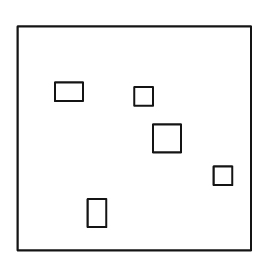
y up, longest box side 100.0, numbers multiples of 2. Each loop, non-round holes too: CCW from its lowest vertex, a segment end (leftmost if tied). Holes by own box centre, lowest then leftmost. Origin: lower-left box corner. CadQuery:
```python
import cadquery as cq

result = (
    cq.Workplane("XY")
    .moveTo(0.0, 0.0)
    .lineTo(100.0, 0.0)
    .lineTo(100.0, 96.0)
    .lineTo(0.0, 96.0)
    .close()
    .moveTo(30.0, 10.0)
    .lineTo(38.0, 10.0)
    .lineTo(38.0, 22.0)
    .lineTo(30.0, 22.0)
    .close()
    .moveTo(84.0, 28.0)
    .lineTo(92.0, 28.0)
    .lineTo(92.0, 36.0)
    .lineTo(84.0, 36.0)
    .close()
    .moveTo(58.0, 42.0)
    .lineTo(70.0, 42.0)
    .lineTo(70.0, 54.0)
    .lineTo(58.0, 54.0)
    .close()
    .moveTo(50.0, 62.0)
    .lineTo(58.0, 62.0)
    .lineTo(58.0, 70.0)
    .lineTo(50.0, 70.0)
    .close()
    .moveTo(16.0, 64.0)
    .lineTo(28.0, 64.0)
    .lineTo(28.0, 72.0)
    .lineTo(16.0, 72.0)
    .close()
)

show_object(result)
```